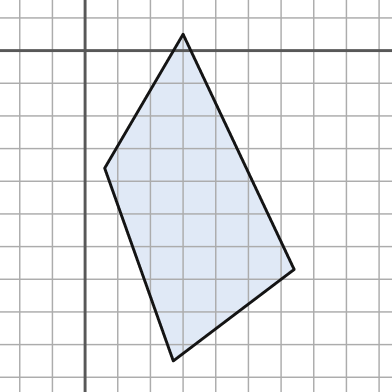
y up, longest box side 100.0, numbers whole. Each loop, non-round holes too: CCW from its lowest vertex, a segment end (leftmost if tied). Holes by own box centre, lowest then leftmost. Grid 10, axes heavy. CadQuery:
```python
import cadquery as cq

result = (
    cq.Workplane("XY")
    .moveTo(27.0, -95.0)
    .lineTo(64.0, -67.0)
    .lineTo(30.0, 5.0)
    .lineTo(6.0, -36.0)
    .close()
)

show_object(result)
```